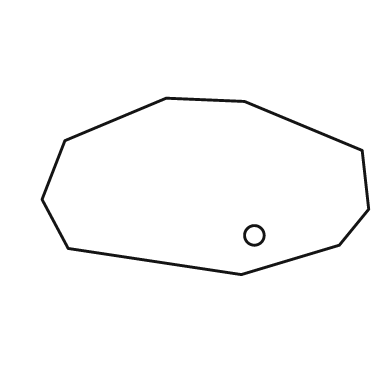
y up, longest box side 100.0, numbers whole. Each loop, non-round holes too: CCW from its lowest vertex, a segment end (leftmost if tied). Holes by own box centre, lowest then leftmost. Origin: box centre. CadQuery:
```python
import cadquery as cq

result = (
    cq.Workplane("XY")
    .moveTo(11.0, -27.0)
    .lineTo(41.0, -18.0)
    .lineTo(50.0, -7.0)
    .lineTo(48.0, 11.0)
    .lineTo(12.0, 26.0)
    .lineTo(-12.0, 27.0)
    .lineTo(-43.0, 14.0)
    .lineTo(-50.0, -4.0)
    .lineTo(-42.0, -19.0)
    .close()
    .moveTo(15.0, -15.0)
    .circle(3.0)
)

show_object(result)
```